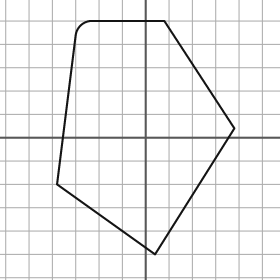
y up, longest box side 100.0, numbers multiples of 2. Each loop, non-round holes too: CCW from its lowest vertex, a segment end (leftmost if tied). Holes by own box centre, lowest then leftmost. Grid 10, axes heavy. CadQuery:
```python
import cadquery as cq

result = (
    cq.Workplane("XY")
    .moveTo(4.0, -50.0)
    .lineTo(38.0, 4.0)
    .lineTo(8.0, 50.0)
    .lineTo(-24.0, 50.0)
    .threePointArc((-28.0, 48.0), (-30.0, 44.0))
    .lineTo(-38.0, -20.0)
    .close()
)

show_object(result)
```